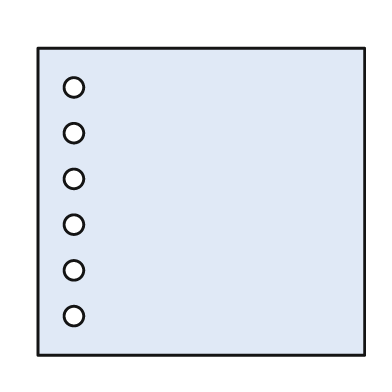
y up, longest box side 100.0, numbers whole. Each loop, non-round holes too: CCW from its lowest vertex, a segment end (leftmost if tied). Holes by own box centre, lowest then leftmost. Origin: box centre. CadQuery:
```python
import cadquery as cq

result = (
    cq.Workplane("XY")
    .moveTo(-50.0, -47.0)
    .lineTo(50.0, -47.0)
    .lineTo(50.0, 47.0)
    .lineTo(-50.0, 47.0)
    .close()
    .moveTo(-39.0, -35.0)
    .circle(3.0)
    .moveTo(-39.0, -21.0)
    .circle(3.0)
    .moveTo(-39.0, -7.0)
    .circle(3.0)
    .moveTo(-39.0, 7.0)
    .circle(3.0)
    .moveTo(-39.0, 21.0)
    .circle(3.0)
    .moveTo(-39.0, 35.0)
    .circle(3.0)
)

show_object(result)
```